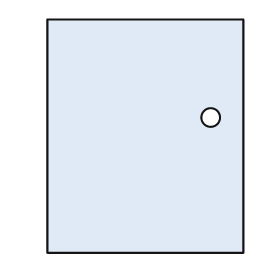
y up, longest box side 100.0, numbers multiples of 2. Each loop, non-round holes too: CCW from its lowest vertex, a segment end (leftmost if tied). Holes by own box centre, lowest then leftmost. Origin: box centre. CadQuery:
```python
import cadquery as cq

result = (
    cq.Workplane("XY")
    .moveTo(-42.0, -50.0)
    .lineTo(42.0, -50.0)
    .lineTo(42.0, 50.0)
    .lineTo(-42.0, 50.0)
    .close()
    .moveTo(28.0, 8.0)
    .circle(4.0)
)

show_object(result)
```